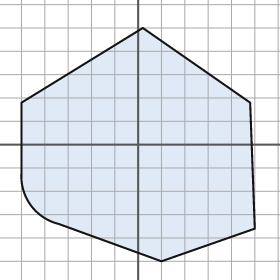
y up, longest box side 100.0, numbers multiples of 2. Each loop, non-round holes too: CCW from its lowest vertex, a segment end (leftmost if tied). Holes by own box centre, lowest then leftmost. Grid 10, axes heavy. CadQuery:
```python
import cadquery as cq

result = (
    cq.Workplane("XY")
    .moveTo(10.0, -50.0)
    .lineTo(50.0, -36.0)
    .lineTo(48.0, 18.0)
    .lineTo(2.0, 50.0)
    .lineTo(-50.0, 18.0)
    .lineTo(-50.0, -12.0)
    .threePointArc((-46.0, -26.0), (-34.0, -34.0))
    .close()
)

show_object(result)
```